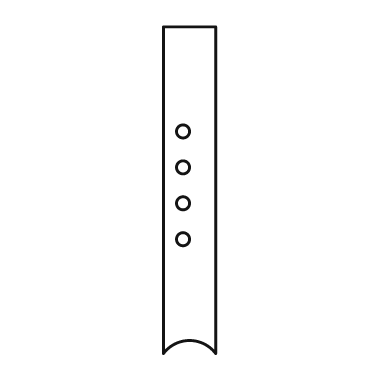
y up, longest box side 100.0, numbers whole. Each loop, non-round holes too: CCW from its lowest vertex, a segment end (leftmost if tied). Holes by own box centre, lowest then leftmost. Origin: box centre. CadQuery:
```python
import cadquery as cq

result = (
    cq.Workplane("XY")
    .moveTo(-8.0, -50.0)
    .threePointArc((0.0, -46.0), (8.0, -50.0))
    .lineTo(8.0, 50.0)
    .lineTo(-8.0, 50.0)
    .close()
    .moveTo(-2.0, -15.0)
    .circle(2.0)
    .moveTo(-2.0, -4.0)
    .circle(2.0)
    .moveTo(-2.0, 7.0)
    .circle(2.0)
    .moveTo(-2.0, 18.0)
    .circle(2.0)
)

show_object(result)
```